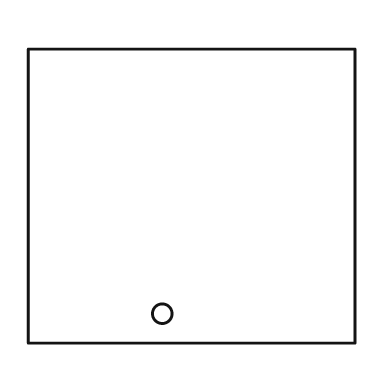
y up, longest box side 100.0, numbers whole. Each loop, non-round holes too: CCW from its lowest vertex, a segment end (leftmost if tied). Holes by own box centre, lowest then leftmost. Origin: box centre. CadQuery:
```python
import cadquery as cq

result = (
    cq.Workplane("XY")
    .moveTo(-50.0, -45.0)
    .lineTo(50.0, -45.0)
    .lineTo(50.0, 45.0)
    .lineTo(-50.0, 45.0)
    .close()
    .moveTo(-9.0, -36.0)
    .circle(3.0)
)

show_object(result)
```